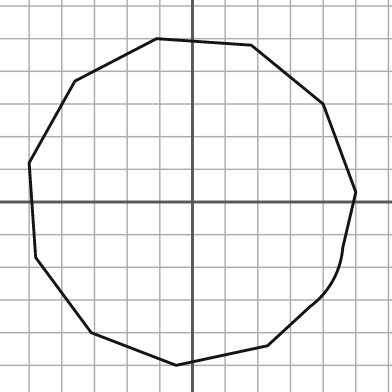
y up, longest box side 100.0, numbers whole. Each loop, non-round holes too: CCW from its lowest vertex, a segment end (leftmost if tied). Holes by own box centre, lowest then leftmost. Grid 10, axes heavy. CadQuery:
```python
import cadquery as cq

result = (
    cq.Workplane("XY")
    .moveTo(-5.0, -50.0)
    .lineTo(23.0, -44.0)
    .lineTo(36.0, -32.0)
    .threePointArc((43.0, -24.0), (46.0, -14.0))
    .lineTo(50.0, 3.0)
    .lineTo(40.0, 30.0)
    .lineTo(18.0, 48.0)
    .lineTo(-11.0, 50.0)
    .lineTo(-36.0, 37.0)
    .lineTo(-50.0, 12.0)
    .lineTo(-48.0, -17.0)
    .lineTo(-31.0, -40.0)
    .close()
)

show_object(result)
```